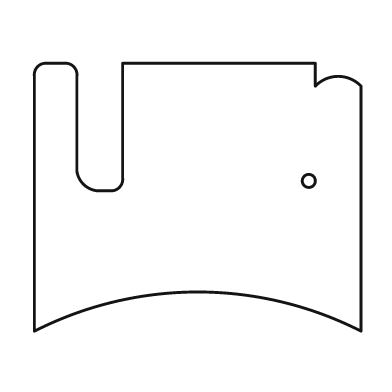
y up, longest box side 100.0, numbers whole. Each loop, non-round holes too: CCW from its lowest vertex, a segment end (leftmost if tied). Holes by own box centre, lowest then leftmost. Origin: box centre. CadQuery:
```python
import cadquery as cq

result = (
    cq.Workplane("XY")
    .moveTo(-50.0, -41.0)
    .threePointArc((0.0, -29.0), (50.0, -41.0))
    .lineTo(50.0, 34.0)
    .threePointArc((43.0, 37.0), (36.0, 34.0))
    .lineTo(36.0, 41.0)
    .lineTo(-23.0, 41.0)
    .lineTo(-23.0, 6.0)
    .threePointArc((-24.0, 3.0), (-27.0, 2.0))
    .lineTo(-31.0, 2.0)
    .threePointArc((-35.0, 4.0), (-37.0, 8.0))
    .lineTo(-37.0, 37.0)
    .threePointArc((-38.0, 40.0), (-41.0, 41.0))
    .lineTo(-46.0, 41.0)
    .threePointArc((-49.0, 40.0), (-50.0, 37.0))
    .close()
    .moveTo(34.0, 5.0)
    .circle(2.0)
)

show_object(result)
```